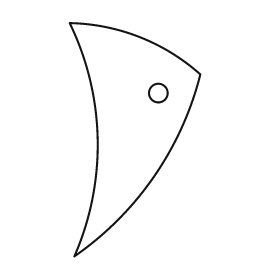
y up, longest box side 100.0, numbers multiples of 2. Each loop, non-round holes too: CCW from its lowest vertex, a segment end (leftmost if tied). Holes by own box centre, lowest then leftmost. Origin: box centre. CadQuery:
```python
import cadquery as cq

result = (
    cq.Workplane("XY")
    .moveTo(-26.0, -50.0)
    .threePointArc((8.0, -16.0), (28.0, 28.0))
    .threePointArc((2.0, 44.0), (-28.0, 50.0))
    .threePointArc((-16.0, 0.0), (-26.0, -50.0))
    .close()
    .moveTo(10.0, 20.0)
    .circle(4.0)
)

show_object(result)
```